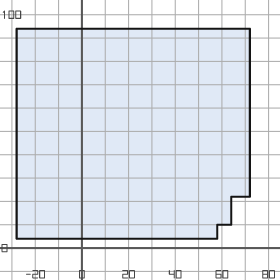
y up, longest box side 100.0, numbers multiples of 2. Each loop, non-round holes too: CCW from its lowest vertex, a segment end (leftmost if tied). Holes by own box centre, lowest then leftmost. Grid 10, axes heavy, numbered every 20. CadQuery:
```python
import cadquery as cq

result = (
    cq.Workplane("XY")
    .moveTo(-28.0, 4.0)
    .lineTo(58.0, 4.0)
    .lineTo(58.0, 10.0)
    .lineTo(64.0, 10.0)
    .lineTo(64.0, 22.0)
    .lineTo(72.0, 22.0)
    .lineTo(72.0, 94.0)
    .lineTo(-28.0, 94.0)
    .close()
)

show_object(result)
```